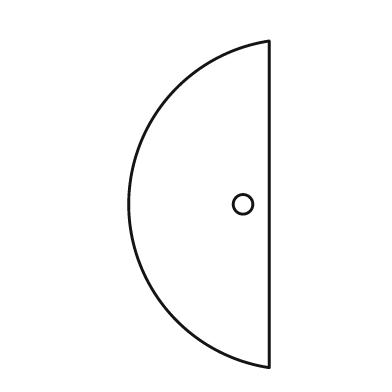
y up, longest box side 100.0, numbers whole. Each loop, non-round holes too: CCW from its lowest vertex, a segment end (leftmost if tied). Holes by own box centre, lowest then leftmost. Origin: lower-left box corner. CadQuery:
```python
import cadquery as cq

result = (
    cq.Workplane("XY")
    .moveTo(43.0, 0.0)
    .lineTo(43.0, 100.0)
    .threePointArc((0.0, 50.0), (43.0, 0.0))
    .close()
    .moveTo(35.0, 50.0)
    .circle(3.0)
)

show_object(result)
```